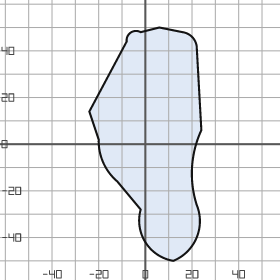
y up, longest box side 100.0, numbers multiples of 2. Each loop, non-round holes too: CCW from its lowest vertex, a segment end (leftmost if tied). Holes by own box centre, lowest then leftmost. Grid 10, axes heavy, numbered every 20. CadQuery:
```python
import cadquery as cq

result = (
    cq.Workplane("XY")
    .moveTo(12.0, -50.0)
    .threePointArc((22.0, -40.0), (22.0, -26.0))
    .threePointArc((20.0, -10.0), (24.0, 6.0))
    .lineTo(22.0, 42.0)
    .threePointArc((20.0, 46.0), (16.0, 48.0))
    .lineTo(6.0, 50.0)
    .lineTo(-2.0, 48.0)
    .threePointArc((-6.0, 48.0), (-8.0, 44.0))
    .lineTo(-24.0, 14.0)
    .lineTo(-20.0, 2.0)
    .threePointArc((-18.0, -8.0), (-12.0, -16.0))
    .lineTo(-2.0, -28.0)
    .threePointArc((0.0, -42.0), (12.0, -50.0))
    .close()
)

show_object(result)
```